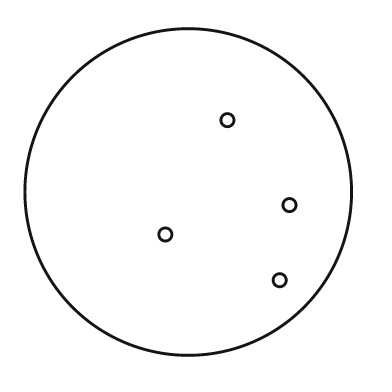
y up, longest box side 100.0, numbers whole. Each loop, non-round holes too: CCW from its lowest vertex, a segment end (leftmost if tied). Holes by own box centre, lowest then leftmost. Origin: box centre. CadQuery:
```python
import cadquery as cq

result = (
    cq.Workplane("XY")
    .moveTo(0.0, 0.0)
    .circle(50.0)
    .moveTo(28.0, -27.0)
    .circle(2.0)
    .moveTo(-7.0, -13.0)
    .circle(2.0)
    .moveTo(31.0, -4.0)
    .circle(2.0)
    .moveTo(12.0, 22.0)
    .circle(2.0)
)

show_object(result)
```